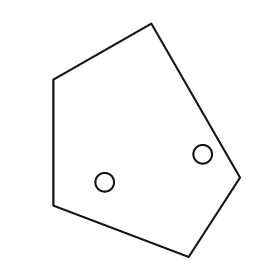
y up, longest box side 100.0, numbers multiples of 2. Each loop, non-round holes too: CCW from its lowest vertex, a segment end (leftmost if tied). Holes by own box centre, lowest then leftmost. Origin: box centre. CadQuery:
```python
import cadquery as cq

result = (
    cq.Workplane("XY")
    .moveTo(18.0, -50.0)
    .lineTo(40.0, -16.0)
    .lineTo(2.0, 50.0)
    .lineTo(-40.0, 26.0)
    .lineTo(-40.0, -28.0)
    .close()
    .moveTo(-18.0, -18.0)
    .circle(4.0)
    .moveTo(24.0, -6.0)
    .circle(4.0)
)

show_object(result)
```